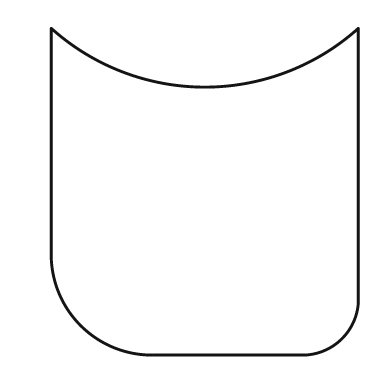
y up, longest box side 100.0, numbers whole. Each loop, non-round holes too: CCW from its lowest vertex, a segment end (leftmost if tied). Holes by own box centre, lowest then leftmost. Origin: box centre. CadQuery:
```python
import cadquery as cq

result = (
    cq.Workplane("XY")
    .moveTo(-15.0, -50.0)
    .lineTo(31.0, -50.0)
    .threePointArc((42.0, -45.0), (47.0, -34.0))
    .lineTo(47.0, 50.0)
    .threePointArc((0.0, 32.0), (-47.0, 50.0))
    .lineTo(-47.0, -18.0)
    .threePointArc((-38.0, -41.0), (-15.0, -50.0))
    .close()
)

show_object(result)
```